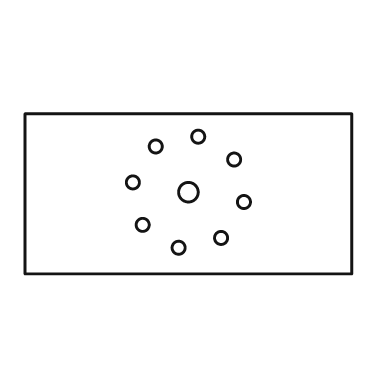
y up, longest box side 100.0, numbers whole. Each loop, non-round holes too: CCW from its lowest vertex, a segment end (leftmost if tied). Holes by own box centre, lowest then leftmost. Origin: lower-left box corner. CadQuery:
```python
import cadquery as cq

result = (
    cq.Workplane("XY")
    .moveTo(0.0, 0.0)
    .lineTo(100.0, 0.0)
    .lineTo(100.0, 49.0)
    .lineTo(0.0, 49.0)
    .close()
    .moveTo(47.0, 8.0)
    .circle(2.0)
    .moveTo(60.0, 11.0)
    .circle(2.0)
    .moveTo(36.0, 15.0)
    .circle(2.0)
    .moveTo(67.0, 22.0)
    .circle(2.0)
    .moveTo(50.0, 25.0)
    .circle(3.0)
    .moveTo(33.0, 28.0)
    .circle(2.0)
    .moveTo(64.0, 35.0)
    .circle(2.0)
    .moveTo(40.0, 39.0)
    .circle(2.0)
    .moveTo(53.0, 42.0)
    .circle(2.0)
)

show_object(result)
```